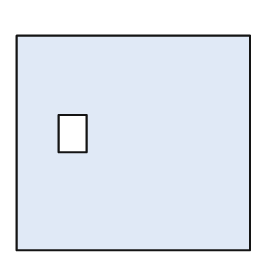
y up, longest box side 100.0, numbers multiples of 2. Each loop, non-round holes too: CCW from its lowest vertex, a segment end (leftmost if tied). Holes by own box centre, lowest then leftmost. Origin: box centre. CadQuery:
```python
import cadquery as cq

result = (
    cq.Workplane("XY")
    .moveTo(-50.0, -46.0)
    .lineTo(50.0, -46.0)
    .lineTo(50.0, 46.0)
    .lineTo(-50.0, 46.0)
    .close()
    .moveTo(-32.0, -4.0)
    .lineTo(-20.0, -4.0)
    .lineTo(-20.0, 12.0)
    .lineTo(-32.0, 12.0)
    .close()
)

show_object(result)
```